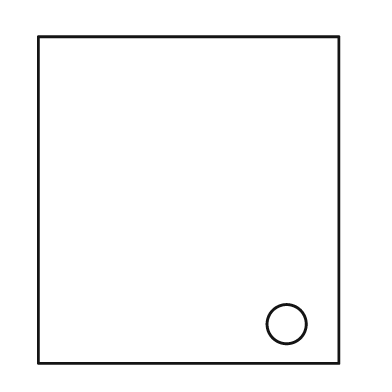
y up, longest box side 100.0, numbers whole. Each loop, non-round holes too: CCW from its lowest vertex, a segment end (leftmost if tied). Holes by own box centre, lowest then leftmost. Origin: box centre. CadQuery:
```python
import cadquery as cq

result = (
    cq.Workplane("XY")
    .moveTo(-46.0, -50.0)
    .lineTo(46.0, -50.0)
    .lineTo(46.0, 50.0)
    .lineTo(-46.0, 50.0)
    .close()
    .moveTo(30.0, -38.0)
    .circle(6.0)
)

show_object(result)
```